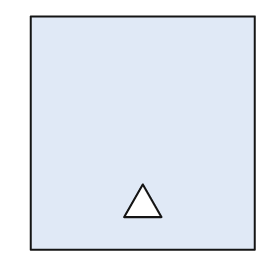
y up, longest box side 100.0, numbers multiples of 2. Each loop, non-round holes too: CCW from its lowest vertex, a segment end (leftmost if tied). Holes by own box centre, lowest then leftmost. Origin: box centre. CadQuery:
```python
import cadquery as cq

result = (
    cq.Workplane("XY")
    .moveTo(-48.0, -50.0)
    .lineTo(48.0, -50.0)
    .lineTo(48.0, 50.0)
    .lineTo(-48.0, 50.0)
    .close()
    .moveTo(-8.0, -36.0)
    .lineTo(8.0, -36.0)
    .lineTo(0.0, -22.0)
    .close()
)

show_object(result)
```